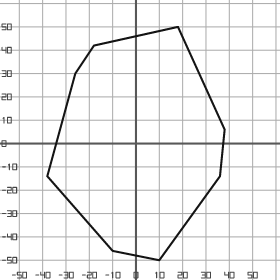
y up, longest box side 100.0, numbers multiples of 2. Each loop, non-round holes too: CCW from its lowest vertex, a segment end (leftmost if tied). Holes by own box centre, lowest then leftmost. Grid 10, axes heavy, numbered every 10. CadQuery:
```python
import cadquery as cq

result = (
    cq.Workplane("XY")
    .moveTo(10.0, -50.0)
    .lineTo(36.0, -14.0)
    .lineTo(38.0, 6.0)
    .lineTo(18.0, 50.0)
    .lineTo(-18.0, 42.0)
    .lineTo(-26.0, 30.0)
    .lineTo(-38.0, -14.0)
    .lineTo(-10.0, -46.0)
    .close()
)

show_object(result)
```